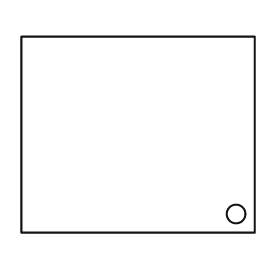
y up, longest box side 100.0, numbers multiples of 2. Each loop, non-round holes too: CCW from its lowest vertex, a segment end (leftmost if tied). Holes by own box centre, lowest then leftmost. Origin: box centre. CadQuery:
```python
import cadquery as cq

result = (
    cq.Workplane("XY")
    .moveTo(-50.0, -42.0)
    .lineTo(50.0, -42.0)
    .lineTo(50.0, 42.0)
    .lineTo(-50.0, 42.0)
    .close()
    .moveTo(42.0, -34.0)
    .circle(4.0)
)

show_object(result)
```